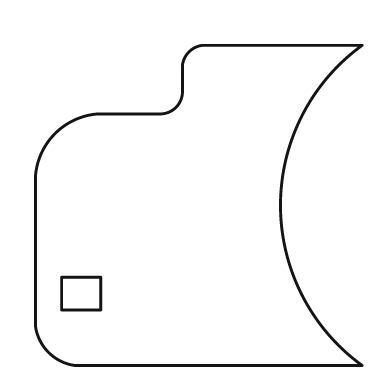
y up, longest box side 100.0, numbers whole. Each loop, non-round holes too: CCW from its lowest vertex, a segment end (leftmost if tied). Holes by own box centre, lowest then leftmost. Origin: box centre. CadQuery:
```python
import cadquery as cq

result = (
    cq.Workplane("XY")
    .moveTo(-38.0, -49.0)
    .lineTo(50.0, -49.0)
    .threePointArc((25.0, 0.0), (50.0, 49.0))
    .lineTo(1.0, 49.0)
    .threePointArc((-3.0, 47.0), (-5.0, 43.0))
    .lineTo(-5.0, 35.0)
    .threePointArc((-7.0, 30.0), (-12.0, 28.0))
    .lineTo(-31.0, 28.0)
    .threePointArc((-44.0, 22.0), (-50.0, 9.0))
    .lineTo(-50.0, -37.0)
    .threePointArc((-46.0, -45.0), (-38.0, -49.0))
    .close()
    .moveTo(-42.0, -32.0)
    .lineTo(-30.0, -32.0)
    .lineTo(-30.0, -22.0)
    .lineTo(-42.0, -22.0)
    .close()
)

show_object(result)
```